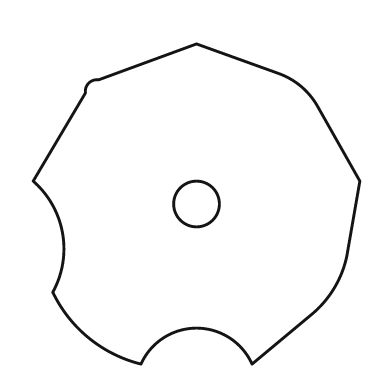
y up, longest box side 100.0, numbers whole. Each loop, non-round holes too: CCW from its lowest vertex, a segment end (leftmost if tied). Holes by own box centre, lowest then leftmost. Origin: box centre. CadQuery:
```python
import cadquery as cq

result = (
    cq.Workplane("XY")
    .moveTo(-17.0, -49.0)
    .threePointArc((0.0, -38.0), (17.0, -49.0))
    .lineTo(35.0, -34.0)
    .threePointArc((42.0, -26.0), (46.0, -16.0))
    .lineTo(50.0, 7.0)
    .lineTo(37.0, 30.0)
    .threePointArc((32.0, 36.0), (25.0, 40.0))
    .lineTo(0.0, 49.0)
    .lineTo(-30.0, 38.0)
    .threePointArc((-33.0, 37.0), (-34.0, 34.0))
    .lineTo(-50.0, 7.0)
    .threePointArc((-41.0, -9.0), (-44.0, -27.0))
    .threePointArc((-33.0, -41.0), (-17.0, -49.0))
    .close()
    .moveTo(0.0, 0.0)
    .circle(7.0)
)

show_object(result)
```